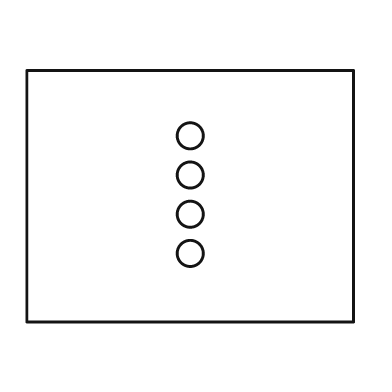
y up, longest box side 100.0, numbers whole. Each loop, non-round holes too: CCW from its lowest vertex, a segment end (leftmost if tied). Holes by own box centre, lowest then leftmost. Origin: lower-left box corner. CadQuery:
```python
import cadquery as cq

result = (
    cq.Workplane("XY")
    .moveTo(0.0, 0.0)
    .lineTo(100.0, 0.0)
    .lineTo(100.0, 77.0)
    .lineTo(0.0, 77.0)
    .close()
    .moveTo(50.0, 21.0)
    .circle(4.0)
    .moveTo(50.0, 33.0)
    .circle(4.0)
    .moveTo(50.0, 45.0)
    .circle(4.0)
    .moveTo(50.0, 57.0)
    .circle(4.0)
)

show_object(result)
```